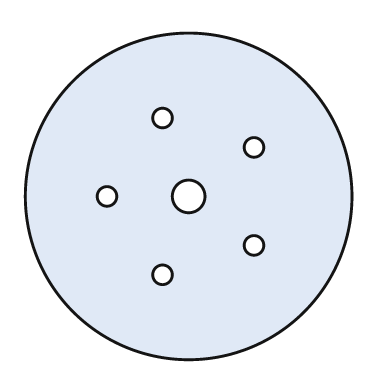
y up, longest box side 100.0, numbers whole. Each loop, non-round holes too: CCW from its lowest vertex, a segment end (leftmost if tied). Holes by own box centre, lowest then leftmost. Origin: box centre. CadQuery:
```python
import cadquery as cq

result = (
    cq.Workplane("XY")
    .moveTo(0.0, 0.0)
    .circle(50.0)
    .moveTo(-8.0, -24.0)
    .circle(3.0)
    .moveTo(20.0, -15.0)
    .circle(3.0)
    .moveTo(-25.0, 0.0)
    .circle(3.0)
    .moveTo(0.0, 0.0)
    .circle(5.0)
    .moveTo(20.0, 15.0)
    .circle(3.0)
    .moveTo(-8.0, 24.0)
    .circle(3.0)
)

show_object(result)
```